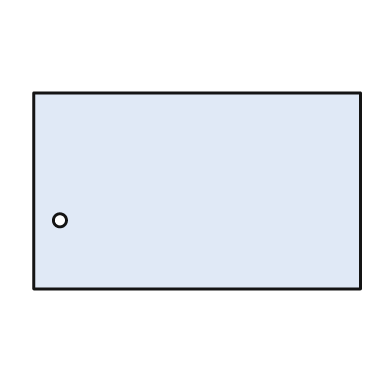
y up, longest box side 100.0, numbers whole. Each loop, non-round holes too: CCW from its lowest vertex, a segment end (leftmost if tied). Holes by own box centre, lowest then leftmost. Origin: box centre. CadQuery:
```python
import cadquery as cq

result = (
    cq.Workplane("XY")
    .moveTo(-50.0, -30.0)
    .lineTo(50.0, -30.0)
    .lineTo(50.0, 30.0)
    .lineTo(-50.0, 30.0)
    .close()
    .moveTo(-42.0, -9.0)
    .circle(2.0)
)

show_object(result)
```